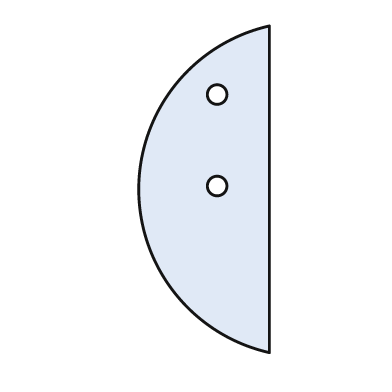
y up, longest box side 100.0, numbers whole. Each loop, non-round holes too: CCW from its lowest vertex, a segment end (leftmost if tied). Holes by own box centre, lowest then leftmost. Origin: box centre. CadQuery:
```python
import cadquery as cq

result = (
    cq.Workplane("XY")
    .moveTo(20.0, -50.0)
    .lineTo(20.0, 50.0)
    .threePointArc((-20.0, 0.0), (20.0, -50.0))
    .close()
    .moveTo(4.0, 1.0)
    .circle(3.0)
    .moveTo(4.0, 29.0)
    .circle(3.0)
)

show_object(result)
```